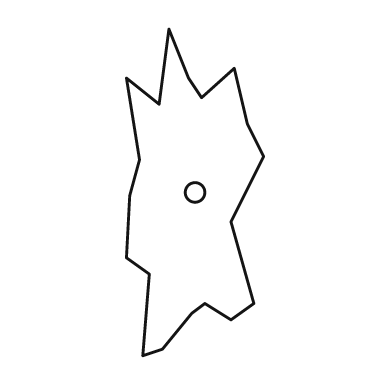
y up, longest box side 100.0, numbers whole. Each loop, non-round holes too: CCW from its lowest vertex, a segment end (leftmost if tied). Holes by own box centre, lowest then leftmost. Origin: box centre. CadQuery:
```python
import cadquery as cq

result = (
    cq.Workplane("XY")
    .moveTo(-16.0, -50.0)
    .lineTo(-10.0, -48.0)
    .lineTo(-1.0, -37.0)
    .lineTo(3.0, -34.0)
    .lineTo(11.0, -39.0)
    .lineTo(18.0, -34.0)
    .lineTo(11.0, -9.0)
    .lineTo(21.0, 11.0)
    .lineTo(16.0, 21.0)
    .lineTo(12.0, 38.0)
    .lineTo(2.0, 29.0)
    .lineTo(-2.0, 35.0)
    .lineTo(-8.0, 50.0)
    .lineTo(-11.0, 27.0)
    .lineTo(-21.0, 35.0)
    .lineTo(-17.0, 10.0)
    .lineTo(-20.0, -1.0)
    .lineTo(-21.0, -20.0)
    .lineTo(-14.0, -25.0)
    .close()
    .moveTo(0.0, 0.0)
    .circle(3.0)
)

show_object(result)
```